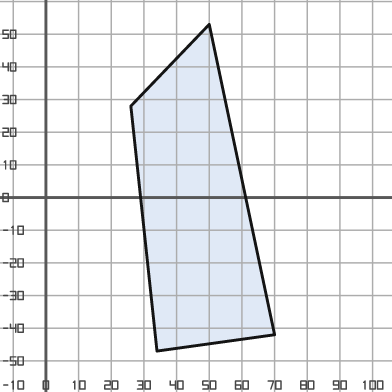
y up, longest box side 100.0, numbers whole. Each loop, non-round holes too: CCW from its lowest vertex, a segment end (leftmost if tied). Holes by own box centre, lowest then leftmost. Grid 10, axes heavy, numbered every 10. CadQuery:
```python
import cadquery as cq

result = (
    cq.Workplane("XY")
    .moveTo(34.0, -47.0)
    .lineTo(70.0, -42.0)
    .lineTo(50.0, 53.0)
    .lineTo(26.0, 28.0)
    .close()
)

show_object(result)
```